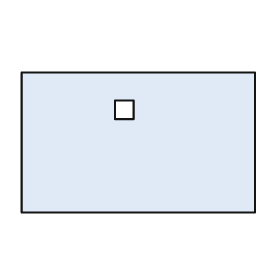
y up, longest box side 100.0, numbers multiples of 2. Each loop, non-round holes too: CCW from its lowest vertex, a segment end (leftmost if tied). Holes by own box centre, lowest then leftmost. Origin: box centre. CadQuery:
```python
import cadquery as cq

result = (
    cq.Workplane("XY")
    .moveTo(-50.0, -30.0)
    .lineTo(50.0, -30.0)
    .lineTo(50.0, 30.0)
    .lineTo(-50.0, 30.0)
    .close()
    .moveTo(-10.0, 10.0)
    .lineTo(-2.0, 10.0)
    .lineTo(-2.0, 18.0)
    .lineTo(-10.0, 18.0)
    .close()
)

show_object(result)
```